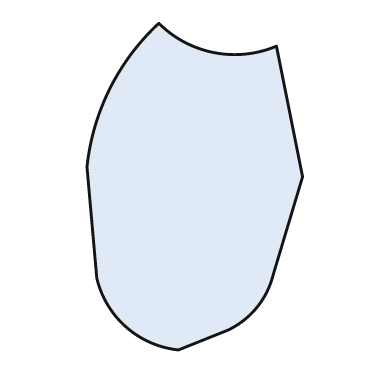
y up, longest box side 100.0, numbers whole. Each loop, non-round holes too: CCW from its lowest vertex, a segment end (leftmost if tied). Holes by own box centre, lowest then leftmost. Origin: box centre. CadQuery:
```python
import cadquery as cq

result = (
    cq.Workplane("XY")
    .moveTo(-5.0, -50.0)
    .lineTo(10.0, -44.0)
    .threePointArc((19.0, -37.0), (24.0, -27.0))
    .lineTo(33.0, 3.0)
    .lineTo(25.0, 43.0)
    .threePointArc((6.0, 41.0), (-11.0, 50.0))
    .threePointArc((-26.0, 30.0), (-33.0, 6.0))
    .lineTo(-30.0, -28.0)
    .threePointArc((-21.0, -43.0), (-5.0, -50.0))
    .close()
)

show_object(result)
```